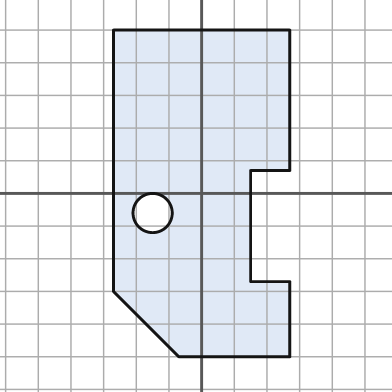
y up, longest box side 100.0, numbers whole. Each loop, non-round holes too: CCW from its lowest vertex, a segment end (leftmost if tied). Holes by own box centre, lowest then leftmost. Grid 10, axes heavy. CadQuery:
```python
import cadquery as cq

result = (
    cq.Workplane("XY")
    .moveTo(-7.0, -50.0)
    .lineTo(27.0, -50.0)
    .lineTo(27.0, -27.0)
    .lineTo(15.0, -27.0)
    .lineTo(15.0, 7.0)
    .lineTo(27.0, 7.0)
    .lineTo(27.0, 50.0)
    .lineTo(-27.0, 50.0)
    .lineTo(-27.0, -30.0)
    .close()
    .moveTo(-15.0, -6.0)
    .circle(6.0)
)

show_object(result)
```